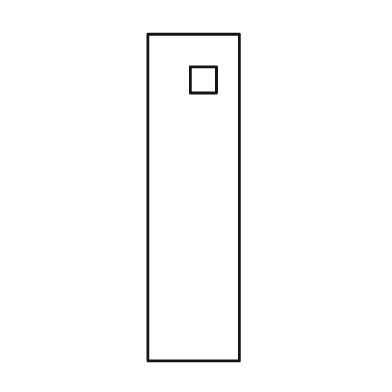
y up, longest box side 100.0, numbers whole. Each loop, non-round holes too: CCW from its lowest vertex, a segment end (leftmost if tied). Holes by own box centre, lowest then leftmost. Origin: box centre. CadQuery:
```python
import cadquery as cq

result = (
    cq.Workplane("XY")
    .moveTo(-14.0, -50.0)
    .lineTo(14.0, -50.0)
    .lineTo(14.0, 50.0)
    .lineTo(-14.0, 50.0)
    .close()
    .moveTo(-1.0, 32.0)
    .lineTo(7.0, 32.0)
    .lineTo(7.0, 40.0)
    .lineTo(-1.0, 40.0)
    .close()
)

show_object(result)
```